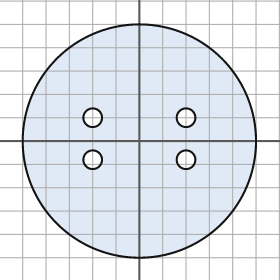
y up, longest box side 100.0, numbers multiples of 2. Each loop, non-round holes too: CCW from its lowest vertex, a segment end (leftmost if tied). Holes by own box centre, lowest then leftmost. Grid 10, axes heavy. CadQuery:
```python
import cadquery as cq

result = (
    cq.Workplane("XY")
    .moveTo(0.0, 0.0)
    .circle(50.0)
    .moveTo(-20.0, -8.0)
    .circle(4.0)
    .moveTo(20.0, -8.0)
    .circle(4.0)
    .moveTo(-20.0, 10.0)
    .circle(4.0)
    .moveTo(20.0, 10.0)
    .circle(4.0)
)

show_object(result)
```